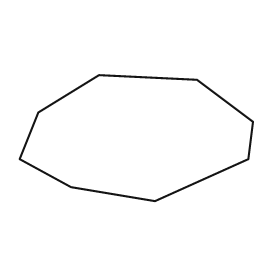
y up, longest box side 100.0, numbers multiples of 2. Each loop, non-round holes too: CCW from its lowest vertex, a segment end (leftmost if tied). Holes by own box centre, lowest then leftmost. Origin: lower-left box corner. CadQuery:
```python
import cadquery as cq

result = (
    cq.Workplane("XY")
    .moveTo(58.0, 0.0)
    .lineTo(98.0, 18.0)
    .lineTo(100.0, 34.0)
    .lineTo(76.0, 52.0)
    .lineTo(34.0, 54.0)
    .lineTo(8.0, 38.0)
    .lineTo(0.0, 18.0)
    .lineTo(22.0, 6.0)
    .close()
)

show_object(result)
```